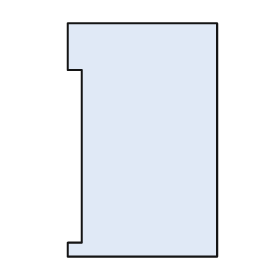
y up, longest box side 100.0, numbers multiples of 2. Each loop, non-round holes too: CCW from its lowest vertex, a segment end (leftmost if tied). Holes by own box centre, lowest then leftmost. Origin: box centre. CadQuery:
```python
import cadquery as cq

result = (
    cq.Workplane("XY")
    .moveTo(-32.0, -50.0)
    .lineTo(32.0, -50.0)
    .lineTo(32.0, 50.0)
    .lineTo(-32.0, 50.0)
    .lineTo(-32.0, 30.0)
    .lineTo(-26.0, 30.0)
    .lineTo(-26.0, -44.0)
    .lineTo(-32.0, -44.0)
    .close()
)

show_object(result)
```